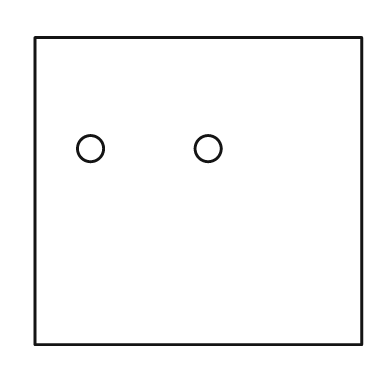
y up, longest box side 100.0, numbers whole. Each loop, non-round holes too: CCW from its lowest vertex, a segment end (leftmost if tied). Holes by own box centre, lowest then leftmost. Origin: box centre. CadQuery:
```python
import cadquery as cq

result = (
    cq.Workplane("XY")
    .moveTo(-50.0, -47.0)
    .lineTo(50.0, -47.0)
    .lineTo(50.0, 47.0)
    .lineTo(-50.0, 47.0)
    .close()
    .moveTo(-33.0, 13.0)
    .circle(4.0)
    .moveTo(3.0, 13.0)
    .circle(4.0)
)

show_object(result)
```